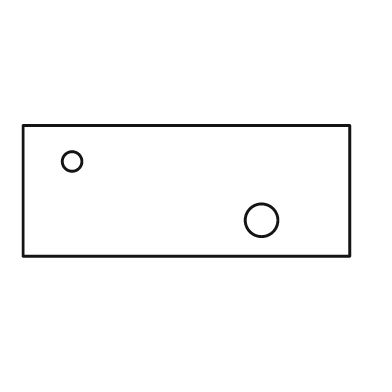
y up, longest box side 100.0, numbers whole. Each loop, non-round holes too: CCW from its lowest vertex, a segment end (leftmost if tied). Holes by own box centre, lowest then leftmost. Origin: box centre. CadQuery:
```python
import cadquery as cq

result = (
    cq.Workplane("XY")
    .moveTo(-50.0, -20.0)
    .lineTo(50.0, -20.0)
    .lineTo(50.0, 20.0)
    .lineTo(-50.0, 20.0)
    .close()
    .moveTo(23.0, -9.0)
    .circle(5.0)
    .moveTo(-35.0, 9.0)
    .circle(3.0)
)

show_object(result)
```